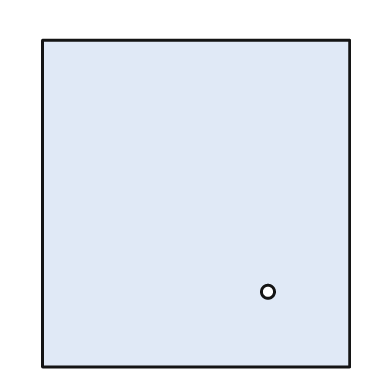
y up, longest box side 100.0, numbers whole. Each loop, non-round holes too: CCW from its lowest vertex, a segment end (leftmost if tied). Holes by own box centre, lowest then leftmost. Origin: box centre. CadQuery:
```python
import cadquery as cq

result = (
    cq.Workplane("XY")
    .moveTo(-47.0, -50.0)
    .lineTo(47.0, -50.0)
    .lineTo(47.0, 50.0)
    .lineTo(-47.0, 50.0)
    .close()
    .moveTo(22.0, -27.0)
    .circle(2.0)
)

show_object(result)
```